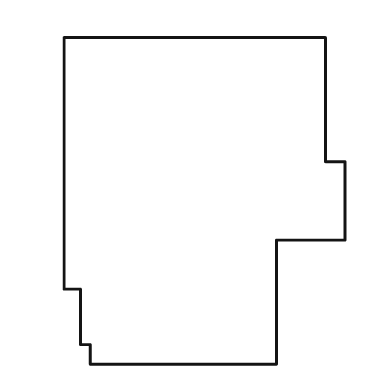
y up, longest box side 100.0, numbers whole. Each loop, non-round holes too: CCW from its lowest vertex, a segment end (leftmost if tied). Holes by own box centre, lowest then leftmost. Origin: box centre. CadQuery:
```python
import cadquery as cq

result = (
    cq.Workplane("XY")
    .moveTo(-35.0, -50.0)
    .lineTo(22.0, -50.0)
    .lineTo(22.0, -12.0)
    .lineTo(43.0, -12.0)
    .lineTo(43.0, 12.0)
    .lineTo(37.0, 12.0)
    .lineTo(37.0, 50.0)
    .lineTo(-43.0, 50.0)
    .lineTo(-43.0, -27.0)
    .lineTo(-38.0, -27.0)
    .lineTo(-38.0, -44.0)
    .lineTo(-35.0, -44.0)
    .close()
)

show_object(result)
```